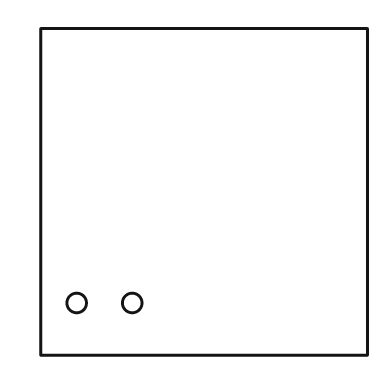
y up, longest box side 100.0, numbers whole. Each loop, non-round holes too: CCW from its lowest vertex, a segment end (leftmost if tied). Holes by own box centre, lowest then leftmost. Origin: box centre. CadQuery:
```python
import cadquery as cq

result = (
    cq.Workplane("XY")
    .moveTo(-50.0, -50.0)
    .lineTo(50.0, -50.0)
    .lineTo(50.0, 50.0)
    .lineTo(-50.0, 50.0)
    .close()
    .moveTo(-39.0, -34.0)
    .circle(3.0)
    .moveTo(-22.0, -34.0)
    .circle(3.0)
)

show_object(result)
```